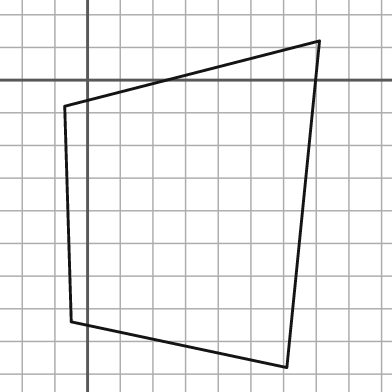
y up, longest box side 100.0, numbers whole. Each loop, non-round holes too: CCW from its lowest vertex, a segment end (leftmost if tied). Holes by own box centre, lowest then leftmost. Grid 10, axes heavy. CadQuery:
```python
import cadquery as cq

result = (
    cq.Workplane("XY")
    .moveTo(61.0, -88.0)
    .lineTo(71.0, 12.0)
    .lineTo(-7.0, -8.0)
    .lineTo(-5.0, -74.0)
    .close()
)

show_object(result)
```